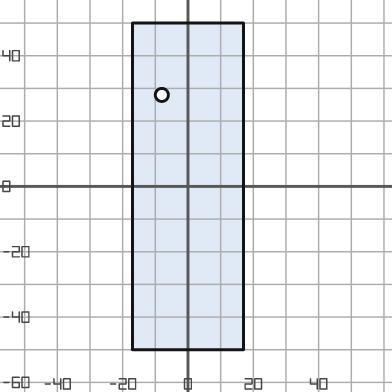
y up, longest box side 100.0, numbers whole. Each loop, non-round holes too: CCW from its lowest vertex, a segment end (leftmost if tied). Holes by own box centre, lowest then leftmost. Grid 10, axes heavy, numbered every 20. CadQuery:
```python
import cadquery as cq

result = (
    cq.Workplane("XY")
    .moveTo(-17.0, -50.0)
    .lineTo(17.0, -50.0)
    .lineTo(17.0, 50.0)
    .lineTo(-17.0, 50.0)
    .close()
    .moveTo(-8.0, 28.0)
    .circle(2.0)
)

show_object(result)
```